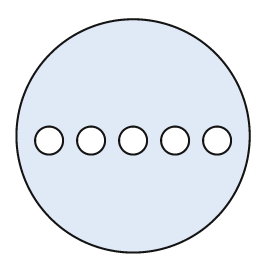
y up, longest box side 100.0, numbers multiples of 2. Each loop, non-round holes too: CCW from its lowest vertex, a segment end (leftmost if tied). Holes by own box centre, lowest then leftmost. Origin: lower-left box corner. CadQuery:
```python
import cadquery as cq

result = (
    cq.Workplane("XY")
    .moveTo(50.0, 50.0)
    .circle(50.0)
    .moveTo(14.0, 48.0)
    .circle(6.0)
    .moveTo(32.0, 48.0)
    .circle(6.0)
    .moveTo(50.0, 48.0)
    .circle(6.0)
    .moveTo(68.0, 48.0)
    .circle(6.0)
    .moveTo(86.0, 48.0)
    .circle(6.0)
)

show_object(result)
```